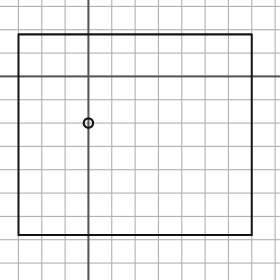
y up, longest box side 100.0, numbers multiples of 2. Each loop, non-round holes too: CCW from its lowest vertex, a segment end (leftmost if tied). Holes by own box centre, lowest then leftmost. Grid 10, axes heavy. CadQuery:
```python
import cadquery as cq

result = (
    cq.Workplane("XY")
    .moveTo(-30.0, -68.0)
    .lineTo(70.0, -68.0)
    .lineTo(70.0, 18.0)
    .lineTo(-30.0, 18.0)
    .close()
    .moveTo(0.0, -20.0)
    .circle(2.0)
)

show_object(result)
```